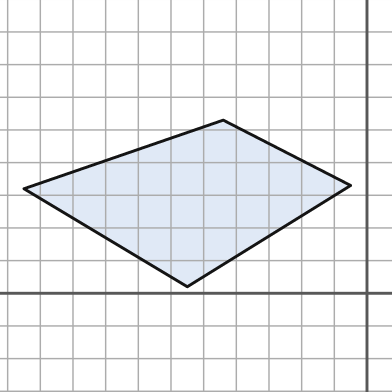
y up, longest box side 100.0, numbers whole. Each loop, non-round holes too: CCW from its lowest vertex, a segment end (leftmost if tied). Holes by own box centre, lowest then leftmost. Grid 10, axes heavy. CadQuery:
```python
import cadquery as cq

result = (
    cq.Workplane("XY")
    .moveTo(-55.0, 2.0)
    .lineTo(-5.0, 33.0)
    .lineTo(-44.0, 53.0)
    .lineTo(-105.0, 32.0)
    .close()
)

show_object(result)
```